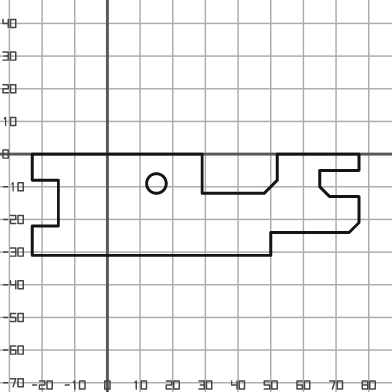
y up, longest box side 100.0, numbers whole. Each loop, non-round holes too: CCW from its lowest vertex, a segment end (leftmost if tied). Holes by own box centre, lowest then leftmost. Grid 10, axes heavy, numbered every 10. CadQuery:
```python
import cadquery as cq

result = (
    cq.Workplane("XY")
    .moveTo(-23.0, -31.0)
    .lineTo(50.0, -31.0)
    .lineTo(50.0, -24.0)
    .lineTo(74.0, -24.0)
    .lineTo(77.0, -21.0)
    .lineTo(77.0, -13.0)
    .lineTo(68.0, -13.0)
    .lineTo(65.0, -10.0)
    .lineTo(65.0, -5.0)
    .lineTo(77.0, -5.0)
    .lineTo(77.0, 0.0)
    .lineTo(52.0, 0.0)
    .lineTo(52.0, -8.0)
    .lineTo(48.0, -12.0)
    .lineTo(29.0, -12.0)
    .lineTo(29.0, 0.0)
    .lineTo(-23.0, 0.0)
    .lineTo(-23.0, -8.0)
    .lineTo(-15.0, -8.0)
    .lineTo(-15.0, -22.0)
    .lineTo(-23.0, -22.0)
    .close()
    .moveTo(15.0, -9.0)
    .circle(3.0)
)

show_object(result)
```